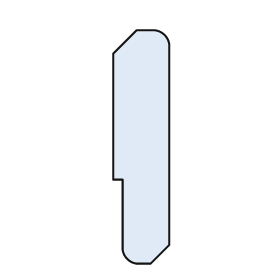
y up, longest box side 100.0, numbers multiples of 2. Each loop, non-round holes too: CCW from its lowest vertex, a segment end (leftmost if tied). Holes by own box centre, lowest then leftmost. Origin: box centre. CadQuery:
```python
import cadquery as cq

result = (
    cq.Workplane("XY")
    .moveTo(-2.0, -50.0)
    .lineTo(4.0, -50.0)
    .lineTo(12.0, -42.0)
    .lineTo(12.0, 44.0)
    .threePointArc((10.0, 48.0), (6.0, 50.0))
    .lineTo(-2.0, 50.0)
    .lineTo(-12.0, 40.0)
    .lineTo(-12.0, -14.0)
    .lineTo(-8.0, -14.0)
    .lineTo(-8.0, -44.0)
    .threePointArc((-6.0, -48.0), (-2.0, -50.0))
    .close()
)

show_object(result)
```